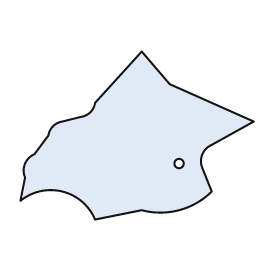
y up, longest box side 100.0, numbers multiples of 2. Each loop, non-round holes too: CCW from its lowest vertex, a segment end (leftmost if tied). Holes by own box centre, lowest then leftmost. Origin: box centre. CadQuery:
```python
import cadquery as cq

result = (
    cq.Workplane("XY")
    .moveTo(-18.0, -36.0)
    .lineTo(2.0, -32.0)
    .threePointArc((18.0, -32.0), (32.0, -24.0))
    .lineTo(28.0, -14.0)
    .threePointArc((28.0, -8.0), (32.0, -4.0))
    .lineTo(50.0, 6.0)
    .lineTo(14.0, 22.0)
    .lineTo(2.0, 36.0)
    .lineTo(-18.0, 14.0)
    .threePointArc((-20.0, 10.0), (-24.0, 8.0))
    .lineTo(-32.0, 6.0)
    .threePointArc((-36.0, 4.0), (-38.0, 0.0))
    .lineTo(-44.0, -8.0)
    .threePointArc((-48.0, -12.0), (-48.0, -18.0))
    .lineTo(-50.0, -28.0)
    .threePointArc((-32.0, -24.0), (-18.0, -36.0))
    .close()
    .moveTo(18.0, -12.0)
    .circle(2.0)
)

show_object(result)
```